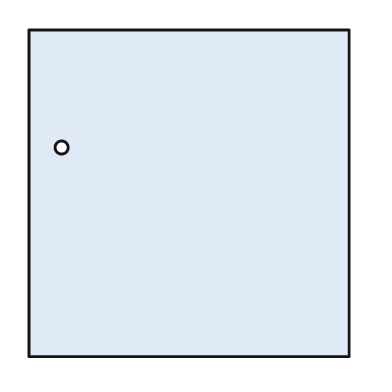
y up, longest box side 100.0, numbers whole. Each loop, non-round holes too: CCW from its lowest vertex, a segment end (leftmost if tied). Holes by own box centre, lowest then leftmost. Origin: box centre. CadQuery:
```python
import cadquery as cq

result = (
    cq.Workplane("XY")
    .moveTo(-49.0, -50.0)
    .lineTo(49.0, -50.0)
    .lineTo(49.0, 50.0)
    .lineTo(-49.0, 50.0)
    .close()
    .moveTo(-39.0, 14.0)
    .circle(2.0)
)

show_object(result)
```